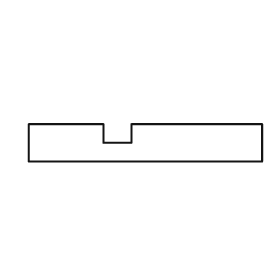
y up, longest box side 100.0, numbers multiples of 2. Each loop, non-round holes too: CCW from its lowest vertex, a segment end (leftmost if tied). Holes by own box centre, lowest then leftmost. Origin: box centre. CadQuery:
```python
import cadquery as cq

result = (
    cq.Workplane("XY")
    .moveTo(-50.0, -8.0)
    .lineTo(50.0, -8.0)
    .lineTo(50.0, 8.0)
    .lineTo(-6.0, 8.0)
    .lineTo(-6.0, 0.0)
    .lineTo(-18.0, 0.0)
    .lineTo(-18.0, 8.0)
    .lineTo(-50.0, 8.0)
    .close()
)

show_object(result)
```